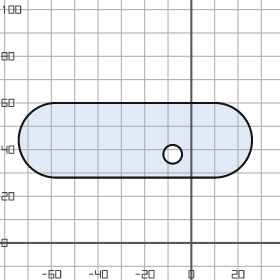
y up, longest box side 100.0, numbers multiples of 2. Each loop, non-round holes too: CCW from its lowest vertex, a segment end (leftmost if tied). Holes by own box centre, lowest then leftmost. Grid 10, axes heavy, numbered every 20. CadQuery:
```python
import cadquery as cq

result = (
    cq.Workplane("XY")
    .moveTo(-58.0, 28.0)
    .lineTo(10.0, 28.0)
    .threePointArc((26.0, 44.0), (10.0, 60.0))
    .lineTo(-58.0, 60.0)
    .threePointArc((-74.0, 44.0), (-58.0, 28.0))
    .close()
    .moveTo(-8.0, 38.0)
    .circle(4.0)
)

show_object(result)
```